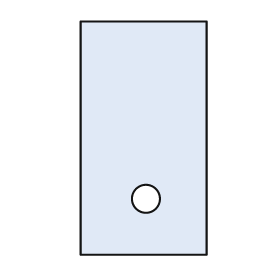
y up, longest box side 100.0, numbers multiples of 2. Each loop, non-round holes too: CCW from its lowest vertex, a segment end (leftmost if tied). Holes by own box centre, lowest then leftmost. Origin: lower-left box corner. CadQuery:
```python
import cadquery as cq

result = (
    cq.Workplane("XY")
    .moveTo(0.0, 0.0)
    .lineTo(54.0, 0.0)
    .lineTo(54.0, 100.0)
    .lineTo(0.0, 100.0)
    .close()
    .moveTo(28.0, 24.0)
    .circle(6.0)
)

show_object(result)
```